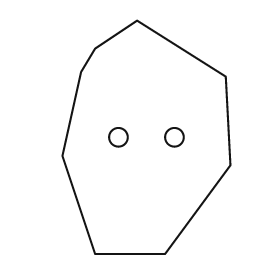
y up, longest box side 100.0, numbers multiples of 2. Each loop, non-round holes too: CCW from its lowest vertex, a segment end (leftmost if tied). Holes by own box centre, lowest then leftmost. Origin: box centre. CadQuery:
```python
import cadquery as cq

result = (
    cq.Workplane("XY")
    .moveTo(-22.0, -50.0)
    .lineTo(8.0, -50.0)
    .lineTo(36.0, -12.0)
    .lineTo(34.0, 26.0)
    .lineTo(-4.0, 50.0)
    .lineTo(-22.0, 38.0)
    .lineTo(-28.0, 28.0)
    .lineTo(-36.0, -8.0)
    .close()
    .moveTo(-12.0, 0.0)
    .circle(4.0)
    .moveTo(12.0, 0.0)
    .circle(4.0)
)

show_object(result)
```